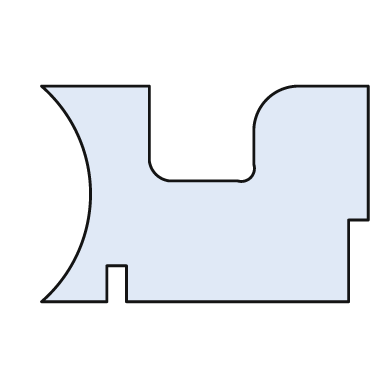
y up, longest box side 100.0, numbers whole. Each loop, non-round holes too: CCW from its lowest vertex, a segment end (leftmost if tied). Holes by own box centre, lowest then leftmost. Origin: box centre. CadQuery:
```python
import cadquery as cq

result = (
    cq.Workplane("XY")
    .moveTo(-50.0, -33.0)
    .lineTo(-30.0, -33.0)
    .lineTo(-30.0, -22.0)
    .lineTo(-24.0, -22.0)
    .lineTo(-24.0, -33.0)
    .lineTo(44.0, -33.0)
    .lineTo(44.0, -8.0)
    .lineTo(50.0, -8.0)
    .lineTo(50.0, 33.0)
    .lineTo(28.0, 33.0)
    .threePointArc((19.0, 29.0), (15.0, 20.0))
    .lineTo(15.0, 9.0)
    .threePointArc((14.0, 5.0), (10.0, 4.0))
    .lineTo(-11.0, 4.0)
    .threePointArc((-15.0, 6.0), (-17.0, 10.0))
    .lineTo(-17.0, 33.0)
    .lineTo(-50.0, 33.0)
    .threePointArc((-35.0, 0.0), (-50.0, -33.0))
    .close()
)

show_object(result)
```